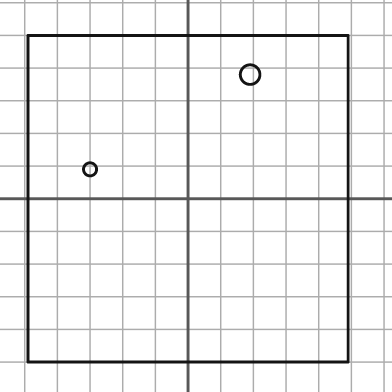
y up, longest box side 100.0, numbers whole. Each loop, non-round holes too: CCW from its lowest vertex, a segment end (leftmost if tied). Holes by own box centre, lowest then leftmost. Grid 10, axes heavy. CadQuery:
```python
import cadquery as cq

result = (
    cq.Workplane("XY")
    .moveTo(-49.0, -50.0)
    .lineTo(49.0, -50.0)
    .lineTo(49.0, 50.0)
    .lineTo(-49.0, 50.0)
    .close()
    .moveTo(-30.0, 9.0)
    .circle(2.0)
    .moveTo(19.0, 38.0)
    .circle(3.0)
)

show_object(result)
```